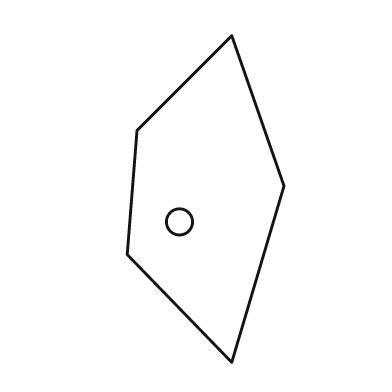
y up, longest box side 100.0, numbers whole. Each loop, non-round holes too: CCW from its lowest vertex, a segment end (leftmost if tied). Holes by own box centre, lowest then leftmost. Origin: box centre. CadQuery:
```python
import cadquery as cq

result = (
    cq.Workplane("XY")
    .moveTo(8.0, -50.0)
    .lineTo(24.0, 4.0)
    .lineTo(8.0, 50.0)
    .lineTo(-21.0, 21.0)
    .lineTo(-24.0, -17.0)
    .close()
    .moveTo(-8.0, -7.0)
    .circle(4.0)
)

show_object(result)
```